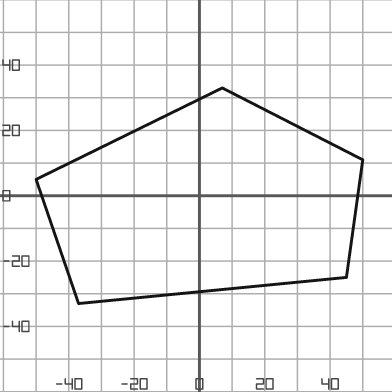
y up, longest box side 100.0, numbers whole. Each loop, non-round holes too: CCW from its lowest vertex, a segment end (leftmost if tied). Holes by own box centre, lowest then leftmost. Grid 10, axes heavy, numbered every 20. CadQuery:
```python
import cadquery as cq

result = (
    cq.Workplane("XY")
    .moveTo(-37.0, -33.0)
    .lineTo(45.0, -25.0)
    .lineTo(50.0, 11.0)
    .lineTo(7.0, 33.0)
    .lineTo(-50.0, 5.0)
    .close()
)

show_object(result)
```